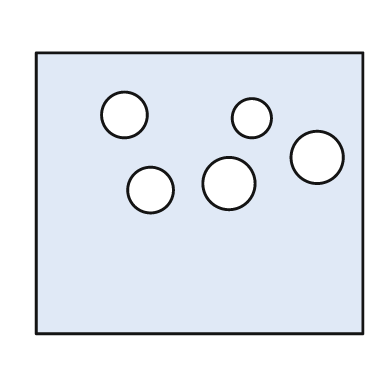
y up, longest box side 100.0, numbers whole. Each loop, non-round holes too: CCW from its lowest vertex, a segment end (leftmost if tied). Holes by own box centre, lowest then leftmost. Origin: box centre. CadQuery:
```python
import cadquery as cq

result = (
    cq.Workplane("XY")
    .moveTo(-50.0, -43.0)
    .lineTo(50.0, -43.0)
    .lineTo(50.0, 43.0)
    .lineTo(-50.0, 43.0)
    .close()
    .moveTo(-15.0, 1.0)
    .circle(7.0)
    .moveTo(9.0, 3.0)
    .circle(8.0)
    .moveTo(36.0, 11.0)
    .circle(8.0)
    .moveTo(16.0, 23.0)
    .circle(6.0)
    .moveTo(-23.0, 24.0)
    .circle(7.0)
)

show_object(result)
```